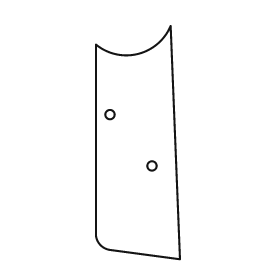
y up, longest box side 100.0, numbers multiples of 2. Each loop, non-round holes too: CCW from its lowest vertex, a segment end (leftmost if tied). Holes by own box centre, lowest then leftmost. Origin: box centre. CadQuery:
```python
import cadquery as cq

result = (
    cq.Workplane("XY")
    .moveTo(18.0, -50.0)
    .lineTo(14.0, 50.0)
    .threePointArc((0.0, 38.0), (-18.0, 42.0))
    .lineTo(-18.0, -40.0)
    .threePointArc((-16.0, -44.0), (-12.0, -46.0))
    .close()
    .moveTo(6.0, -10.0)
    .circle(2.0)
    .moveTo(-12.0, 12.0)
    .circle(2.0)
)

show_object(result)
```